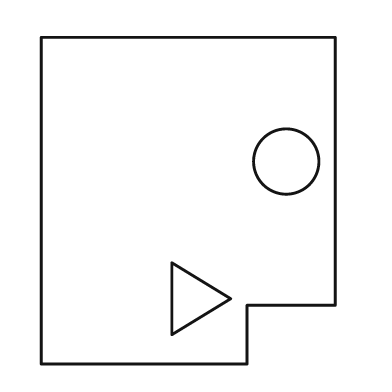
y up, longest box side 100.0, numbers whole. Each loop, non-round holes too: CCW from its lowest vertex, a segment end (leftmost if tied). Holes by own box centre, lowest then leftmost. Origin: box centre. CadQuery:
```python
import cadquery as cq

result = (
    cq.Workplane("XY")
    .moveTo(-45.0, -50.0)
    .lineTo(18.0, -50.0)
    .lineTo(18.0, -32.0)
    .lineTo(45.0, -32.0)
    .lineTo(45.0, 50.0)
    .lineTo(-45.0, 50.0)
    .close()
    .moveTo(-5.0, -41.0)
    .lineTo(13.0, -30.0)
    .lineTo(-5.0, -19.0)
    .close()
    .moveTo(30.0, 12.0)
    .circle(10.0)
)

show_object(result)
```